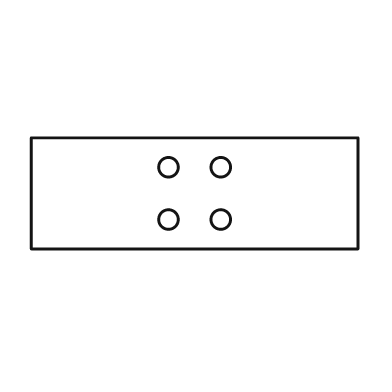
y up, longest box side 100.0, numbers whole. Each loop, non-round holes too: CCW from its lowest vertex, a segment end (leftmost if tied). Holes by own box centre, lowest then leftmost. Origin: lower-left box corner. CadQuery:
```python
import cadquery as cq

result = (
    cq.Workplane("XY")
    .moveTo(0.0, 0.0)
    .lineTo(100.0, 0.0)
    .lineTo(100.0, 34.0)
    .lineTo(0.0, 34.0)
    .close()
    .moveTo(42.0, 9.0)
    .circle(3.0)
    .moveTo(58.0, 9.0)
    .circle(3.0)
    .moveTo(42.0, 25.0)
    .circle(3.0)
    .moveTo(58.0, 25.0)
    .circle(3.0)
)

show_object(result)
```